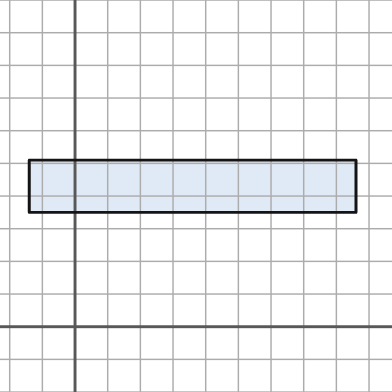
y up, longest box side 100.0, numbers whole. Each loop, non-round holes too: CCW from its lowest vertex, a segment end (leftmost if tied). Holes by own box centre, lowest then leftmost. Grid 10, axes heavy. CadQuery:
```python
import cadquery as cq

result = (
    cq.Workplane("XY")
    .moveTo(-14.0, 35.0)
    .lineTo(86.0, 35.0)
    .lineTo(86.0, 51.0)
    .lineTo(-14.0, 51.0)
    .close()
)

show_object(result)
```